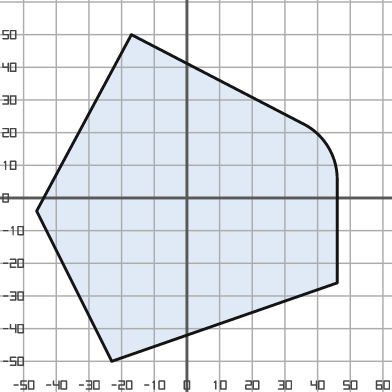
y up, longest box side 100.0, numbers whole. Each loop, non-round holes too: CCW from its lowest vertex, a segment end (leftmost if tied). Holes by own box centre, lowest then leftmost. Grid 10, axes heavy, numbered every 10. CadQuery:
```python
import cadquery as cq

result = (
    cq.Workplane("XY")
    .moveTo(-23.0, -50.0)
    .lineTo(46.0, -26.0)
    .lineTo(46.0, 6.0)
    .threePointArc((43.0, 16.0), (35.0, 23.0))
    .lineTo(-17.0, 50.0)
    .lineTo(-46.0, -4.0)
    .close()
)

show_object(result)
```